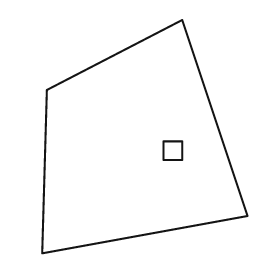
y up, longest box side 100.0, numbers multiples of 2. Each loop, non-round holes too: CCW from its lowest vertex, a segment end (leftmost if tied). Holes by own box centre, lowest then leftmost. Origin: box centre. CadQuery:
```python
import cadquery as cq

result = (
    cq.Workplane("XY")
    .moveTo(-44.0, -50.0)
    .lineTo(44.0, -34.0)
    .lineTo(16.0, 50.0)
    .lineTo(-42.0, 20.0)
    .close()
    .moveTo(8.0, -10.0)
    .lineTo(16.0, -10.0)
    .lineTo(16.0, -2.0)
    .lineTo(8.0, -2.0)
    .close()
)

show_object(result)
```